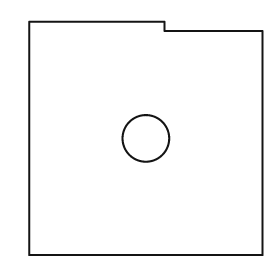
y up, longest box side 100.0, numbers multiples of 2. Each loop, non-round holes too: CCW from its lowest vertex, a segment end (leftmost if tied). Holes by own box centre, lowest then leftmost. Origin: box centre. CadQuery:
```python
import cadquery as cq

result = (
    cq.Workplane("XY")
    .moveTo(-50.0, -50.0)
    .lineTo(50.0, -50.0)
    .lineTo(50.0, 46.0)
    .lineTo(8.0, 46.0)
    .lineTo(8.0, 50.0)
    .lineTo(-50.0, 50.0)
    .close()
    .moveTo(0.0, 0.0)
    .circle(10.0)
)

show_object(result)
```